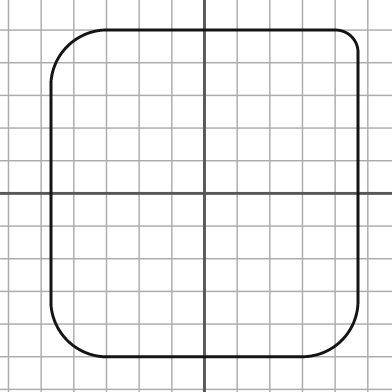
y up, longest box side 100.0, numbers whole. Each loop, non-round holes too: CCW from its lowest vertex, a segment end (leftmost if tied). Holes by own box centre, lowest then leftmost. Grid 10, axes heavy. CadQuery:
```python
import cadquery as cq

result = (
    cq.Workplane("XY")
    .moveTo(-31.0, -50.0)
    .lineTo(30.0, -50.0)
    .threePointArc((42.0, -45.0), (47.0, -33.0))
    .lineTo(47.0, 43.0)
    .threePointArc((45.0, 48.0), (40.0, 50.0))
    .lineTo(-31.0, 50.0)
    .threePointArc((-42.0, 45.0), (-47.0, 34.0))
    .lineTo(-47.0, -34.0)
    .threePointArc((-42.0, -45.0), (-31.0, -50.0))
    .close()
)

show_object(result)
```